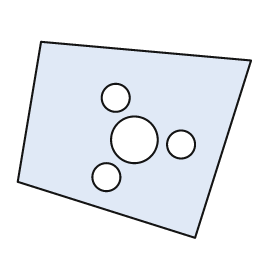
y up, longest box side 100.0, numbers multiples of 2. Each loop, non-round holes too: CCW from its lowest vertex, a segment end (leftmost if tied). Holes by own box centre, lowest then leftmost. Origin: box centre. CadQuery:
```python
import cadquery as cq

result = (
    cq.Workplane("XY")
    .moveTo(26.0, -42.0)
    .lineTo(50.0, 34.0)
    .lineTo(-40.0, 42.0)
    .lineTo(-50.0, -18.0)
    .close()
    .moveTo(-12.0, -16.0)
    .circle(6.0)
    .moveTo(20.0, -2.0)
    .circle(6.0)
    .moveTo(0.0, 0.0)
    .circle(10.0)
    .moveTo(-8.0, 18.0)
    .circle(6.0)
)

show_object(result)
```